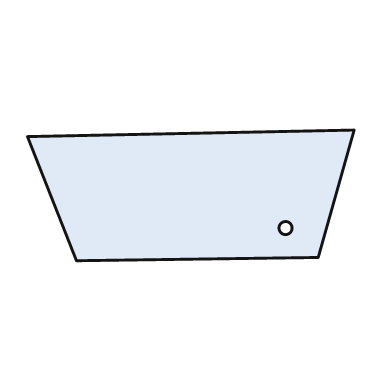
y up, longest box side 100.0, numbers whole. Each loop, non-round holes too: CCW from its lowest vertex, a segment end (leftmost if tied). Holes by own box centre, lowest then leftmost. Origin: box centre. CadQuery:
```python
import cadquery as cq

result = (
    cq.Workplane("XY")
    .moveTo(-35.0, -20.0)
    .lineTo(39.0, -19.0)
    .lineTo(50.0, 20.0)
    .lineTo(-50.0, 18.0)
    .close()
    .moveTo(29.0, -10.0)
    .circle(2.0)
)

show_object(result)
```